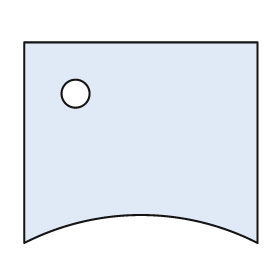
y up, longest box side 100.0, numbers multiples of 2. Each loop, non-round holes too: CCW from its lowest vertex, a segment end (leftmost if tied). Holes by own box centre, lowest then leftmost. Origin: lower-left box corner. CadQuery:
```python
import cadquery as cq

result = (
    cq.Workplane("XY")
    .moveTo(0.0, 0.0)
    .threePointArc((50.0, 12.0), (100.0, 0.0))
    .lineTo(100.0, 86.0)
    .lineTo(0.0, 86.0)
    .close()
    .moveTo(22.0, 64.0)
    .circle(6.0)
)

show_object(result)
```